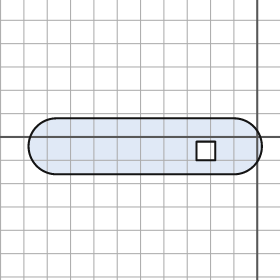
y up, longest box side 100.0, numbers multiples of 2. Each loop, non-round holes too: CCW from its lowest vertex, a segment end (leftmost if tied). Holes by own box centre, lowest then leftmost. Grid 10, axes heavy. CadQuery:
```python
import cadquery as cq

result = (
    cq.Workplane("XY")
    .moveTo(-86.0, -16.0)
    .lineTo(-10.0, -16.0)
    .threePointArc((2.0, -4.0), (-10.0, 8.0))
    .lineTo(-86.0, 8.0)
    .threePointArc((-98.0, -4.0), (-86.0, -16.0))
    .close()
    .moveTo(-26.0, -10.0)
    .lineTo(-18.0, -10.0)
    .lineTo(-18.0, -2.0)
    .lineTo(-26.0, -2.0)
    .close()
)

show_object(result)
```